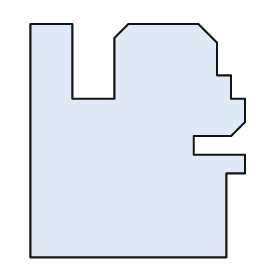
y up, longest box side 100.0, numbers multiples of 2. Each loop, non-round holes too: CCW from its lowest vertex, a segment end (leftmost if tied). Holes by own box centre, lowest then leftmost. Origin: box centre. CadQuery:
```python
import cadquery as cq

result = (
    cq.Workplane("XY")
    .moveTo(-46.0, -50.0)
    .lineTo(38.0, -50.0)
    .lineTo(38.0, -14.0)
    .lineTo(46.0, -14.0)
    .lineTo(46.0, -6.0)
    .lineTo(24.0, -6.0)
    .lineTo(24.0, 2.0)
    .lineTo(40.0, 2.0)
    .lineTo(46.0, 8.0)
    .lineTo(46.0, 18.0)
    .lineTo(40.0, 18.0)
    .lineTo(40.0, 28.0)
    .lineTo(34.0, 28.0)
    .lineTo(34.0, 42.0)
    .lineTo(26.0, 50.0)
    .lineTo(-4.0, 50.0)
    .lineTo(-10.0, 44.0)
    .lineTo(-10.0, 18.0)
    .lineTo(-28.0, 18.0)
    .lineTo(-28.0, 50.0)
    .lineTo(-46.0, 50.0)
    .close()
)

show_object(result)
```